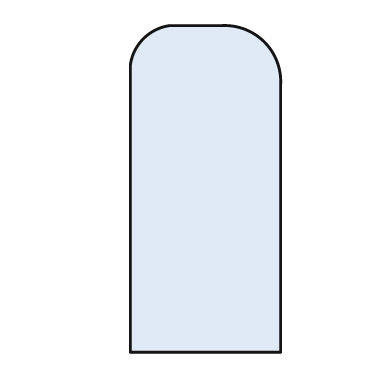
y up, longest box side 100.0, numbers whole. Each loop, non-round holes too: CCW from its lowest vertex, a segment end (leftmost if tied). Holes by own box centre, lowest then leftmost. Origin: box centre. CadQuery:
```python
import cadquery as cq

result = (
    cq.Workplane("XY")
    .moveTo(-23.0, -50.0)
    .lineTo(23.0, -50.0)
    .lineTo(23.0, 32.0)
    .threePointArc((18.0, 45.0), (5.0, 50.0))
    .lineTo(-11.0, 50.0)
    .threePointArc((-19.0, 46.0), (-23.0, 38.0))
    .close()
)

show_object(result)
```